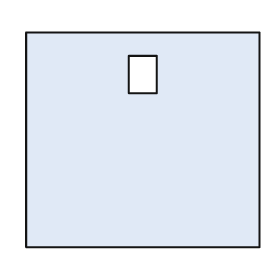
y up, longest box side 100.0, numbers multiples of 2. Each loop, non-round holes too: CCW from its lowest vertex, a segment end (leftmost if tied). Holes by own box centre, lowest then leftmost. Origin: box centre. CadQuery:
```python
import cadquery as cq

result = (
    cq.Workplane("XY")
    .moveTo(-50.0, -46.0)
    .lineTo(50.0, -46.0)
    .lineTo(50.0, 46.0)
    .lineTo(-50.0, 46.0)
    .close()
    .moveTo(-6.0, 20.0)
    .lineTo(6.0, 20.0)
    .lineTo(6.0, 36.0)
    .lineTo(-6.0, 36.0)
    .close()
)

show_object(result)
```